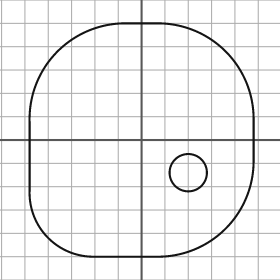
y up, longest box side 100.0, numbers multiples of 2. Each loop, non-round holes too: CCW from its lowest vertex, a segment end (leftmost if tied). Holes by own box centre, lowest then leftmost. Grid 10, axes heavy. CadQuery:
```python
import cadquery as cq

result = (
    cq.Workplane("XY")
    .moveTo(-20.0, -50.0)
    .lineTo(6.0, -50.0)
    .threePointArc((36.0, -38.0), (48.0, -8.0))
    .lineTo(48.0, 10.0)
    .threePointArc((36.0, 38.0), (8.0, 50.0))
    .lineTo(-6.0, 50.0)
    .threePointArc((-36.0, 38.0), (-48.0, 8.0))
    .lineTo(-48.0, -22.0)
    .threePointArc((-40.0, -42.0), (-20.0, -50.0))
    .close()
    .moveTo(20.0, -14.0)
    .circle(8.0)
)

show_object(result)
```